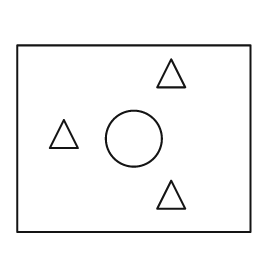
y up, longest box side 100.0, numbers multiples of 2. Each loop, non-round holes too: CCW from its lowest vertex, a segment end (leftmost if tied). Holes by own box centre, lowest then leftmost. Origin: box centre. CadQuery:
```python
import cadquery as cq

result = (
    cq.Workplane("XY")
    .moveTo(-50.0, -40.0)
    .lineTo(50.0, -40.0)
    .lineTo(50.0, 40.0)
    .lineTo(-50.0, 40.0)
    .close()
    .moveTo(10.0, -30.0)
    .lineTo(22.0, -30.0)
    .lineTo(16.0, -18.0)
    .close()
    .moveTo(0.0, 0.0)
    .circle(12.0)
    .moveTo(-36.0, -4.0)
    .lineTo(-24.0, -4.0)
    .lineTo(-30.0, 8.0)
    .close()
    .moveTo(10.0, 22.0)
    .lineTo(22.0, 22.0)
    .lineTo(16.0, 34.0)
    .close()
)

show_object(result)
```